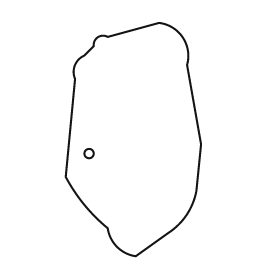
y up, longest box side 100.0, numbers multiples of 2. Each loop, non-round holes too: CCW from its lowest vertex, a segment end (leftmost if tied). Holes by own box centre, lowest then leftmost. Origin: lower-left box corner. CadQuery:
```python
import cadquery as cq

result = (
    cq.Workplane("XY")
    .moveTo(30.0, 0.0)
    .lineTo(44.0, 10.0)
    .threePointArc((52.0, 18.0), (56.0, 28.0))
    .lineTo(58.0, 48.0)
    .lineTo(52.0, 82.0)
    .threePointArc((50.0, 94.0), (40.0, 100.0))
    .lineTo(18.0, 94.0)
    .threePointArc((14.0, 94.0), (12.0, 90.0))
    .lineTo(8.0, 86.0)
    .threePointArc((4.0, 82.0), (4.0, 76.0))
    .lineTo(0.0, 34.0)
    .threePointArc((8.0, 22.0), (18.0, 12.0))
    .threePointArc((22.0, 4.0), (30.0, 0.0))
    .close()
    .moveTo(10.0, 44.0)
    .circle(2.0)
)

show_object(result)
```